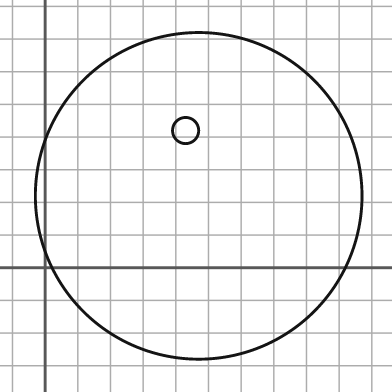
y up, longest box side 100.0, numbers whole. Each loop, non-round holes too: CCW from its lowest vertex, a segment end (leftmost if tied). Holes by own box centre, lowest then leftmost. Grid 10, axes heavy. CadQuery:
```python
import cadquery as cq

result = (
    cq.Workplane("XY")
    .moveTo(47.0, 22.0)
    .circle(50.0)
    .moveTo(43.0, 42.0)
    .circle(4.0)
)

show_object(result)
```